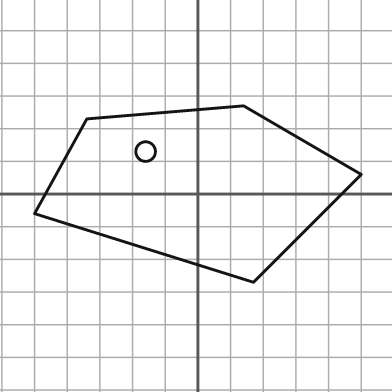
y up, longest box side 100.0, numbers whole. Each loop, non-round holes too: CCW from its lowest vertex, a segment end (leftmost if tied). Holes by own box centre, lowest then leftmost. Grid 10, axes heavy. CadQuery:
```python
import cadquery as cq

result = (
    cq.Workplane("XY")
    .moveTo(17.0, -27.0)
    .lineTo(50.0, 6.0)
    .lineTo(14.0, 27.0)
    .lineTo(-34.0, 23.0)
    .lineTo(-50.0, -6.0)
    .close()
    .moveTo(-16.0, 13.0)
    .circle(3.0)
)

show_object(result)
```